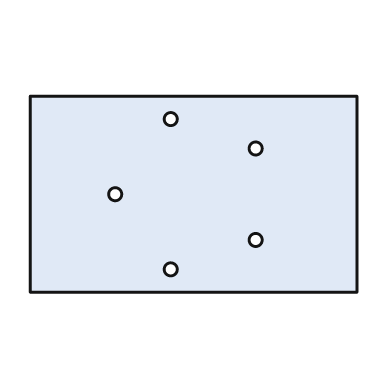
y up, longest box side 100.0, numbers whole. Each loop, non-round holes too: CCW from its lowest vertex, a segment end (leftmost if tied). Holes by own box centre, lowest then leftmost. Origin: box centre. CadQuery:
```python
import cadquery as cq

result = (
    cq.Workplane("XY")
    .moveTo(-50.0, -30.0)
    .lineTo(50.0, -30.0)
    .lineTo(50.0, 30.0)
    .lineTo(-50.0, 30.0)
    .close()
    .moveTo(-7.0, -23.0)
    .circle(2.0)
    .moveTo(19.0, -14.0)
    .circle(2.0)
    .moveTo(-24.0, 0.0)
    .circle(2.0)
    .moveTo(19.0, 14.0)
    .circle(2.0)
    .moveTo(-7.0, 23.0)
    .circle(2.0)
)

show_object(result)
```